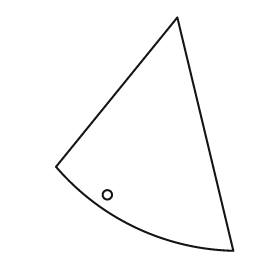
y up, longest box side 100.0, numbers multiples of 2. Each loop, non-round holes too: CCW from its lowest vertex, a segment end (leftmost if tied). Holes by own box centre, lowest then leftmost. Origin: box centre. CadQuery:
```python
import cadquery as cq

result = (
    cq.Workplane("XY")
    .moveTo(38.0, -50.0)
    .lineTo(14.0, 50.0)
    .lineTo(-38.0, -14.0)
    .threePointArc((-4.0, -40.0), (38.0, -50.0))
    .close()
    .moveTo(-16.0, -26.0)
    .circle(2.0)
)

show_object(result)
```